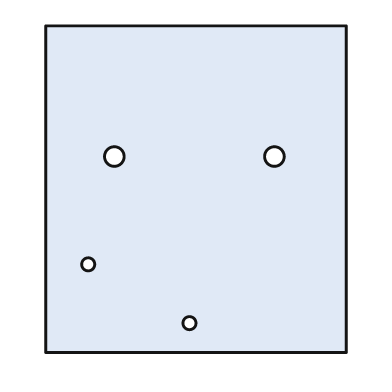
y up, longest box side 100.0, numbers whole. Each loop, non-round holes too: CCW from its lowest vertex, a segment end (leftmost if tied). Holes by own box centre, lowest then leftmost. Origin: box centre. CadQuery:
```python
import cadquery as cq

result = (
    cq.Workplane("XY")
    .moveTo(-46.0, -50.0)
    .lineTo(46.0, -50.0)
    .lineTo(46.0, 50.0)
    .lineTo(-46.0, 50.0)
    .close()
    .moveTo(-2.0, -41.0)
    .circle(2.0)
    .moveTo(-33.0, -23.0)
    .circle(2.0)
    .moveTo(-25.0, 10.0)
    .circle(3.0)
    .moveTo(24.0, 10.0)
    .circle(3.0)
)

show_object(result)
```